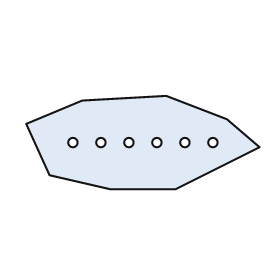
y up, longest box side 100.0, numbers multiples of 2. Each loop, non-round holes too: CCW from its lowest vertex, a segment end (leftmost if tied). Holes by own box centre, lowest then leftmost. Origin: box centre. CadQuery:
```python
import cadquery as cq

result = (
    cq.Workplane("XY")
    .moveTo(-14.0, -20.0)
    .lineTo(14.0, -20.0)
    .lineTo(50.0, -2.0)
    .lineTo(36.0, 10.0)
    .lineTo(10.0, 20.0)
    .lineTo(-26.0, 18.0)
    .lineTo(-50.0, 8.0)
    .lineTo(-40.0, -14.0)
    .close()
    .moveTo(-30.0, 0.0)
    .circle(2.0)
    .moveTo(-18.0, 0.0)
    .circle(2.0)
    .moveTo(-6.0, 0.0)
    .circle(2.0)
    .moveTo(6.0, 0.0)
    .circle(2.0)
    .moveTo(18.0, 0.0)
    .circle(2.0)
    .moveTo(30.0, 0.0)
    .circle(2.0)
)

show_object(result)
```